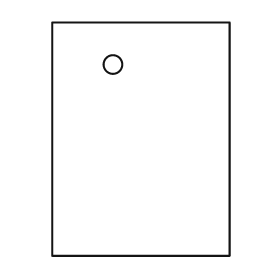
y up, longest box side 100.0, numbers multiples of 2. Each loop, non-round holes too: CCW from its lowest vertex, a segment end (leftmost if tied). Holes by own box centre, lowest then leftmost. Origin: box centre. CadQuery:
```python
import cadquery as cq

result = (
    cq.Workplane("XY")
    .moveTo(-38.0, -50.0)
    .lineTo(38.0, -50.0)
    .lineTo(38.0, 50.0)
    .lineTo(-38.0, 50.0)
    .close()
    .moveTo(-12.0, 32.0)
    .circle(4.0)
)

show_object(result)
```